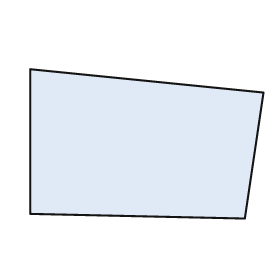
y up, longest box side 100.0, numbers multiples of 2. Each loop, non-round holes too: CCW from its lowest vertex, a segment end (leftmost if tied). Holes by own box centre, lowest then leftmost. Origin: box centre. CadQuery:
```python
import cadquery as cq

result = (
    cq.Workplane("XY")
    .moveTo(42.0, -32.0)
    .lineTo(50.0, 22.0)
    .lineTo(-50.0, 32.0)
    .lineTo(-50.0, -30.0)
    .close()
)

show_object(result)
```